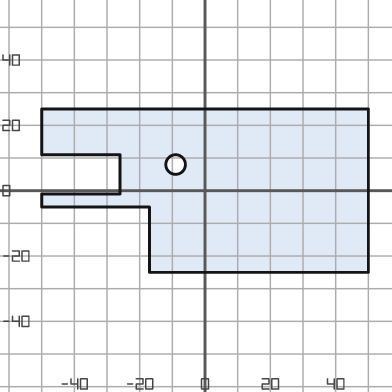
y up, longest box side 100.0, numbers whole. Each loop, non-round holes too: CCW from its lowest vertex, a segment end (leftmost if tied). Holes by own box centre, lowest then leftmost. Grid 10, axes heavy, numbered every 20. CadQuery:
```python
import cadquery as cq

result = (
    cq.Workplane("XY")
    .moveTo(-17.0, -25.0)
    .lineTo(50.0, -25.0)
    .lineTo(50.0, 25.0)
    .lineTo(-50.0, 25.0)
    .lineTo(-50.0, 11.0)
    .lineTo(-26.0, 11.0)
    .lineTo(-26.0, -1.0)
    .lineTo(-50.0, -1.0)
    .lineTo(-50.0, -5.0)
    .lineTo(-17.0, -5.0)
    .close()
    .moveTo(-9.0, 8.0)
    .circle(3.0)
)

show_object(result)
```